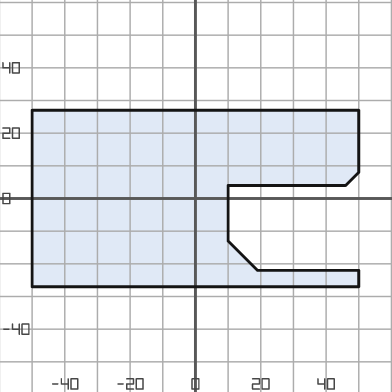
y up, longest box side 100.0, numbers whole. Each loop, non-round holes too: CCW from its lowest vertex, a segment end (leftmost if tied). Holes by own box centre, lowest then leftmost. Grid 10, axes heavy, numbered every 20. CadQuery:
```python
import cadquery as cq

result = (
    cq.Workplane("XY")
    .moveTo(-50.0, -27.0)
    .lineTo(50.0, -27.0)
    .lineTo(50.0, -22.0)
    .lineTo(19.0, -22.0)
    .lineTo(10.0, -13.0)
    .lineTo(10.0, 4.0)
    .lineTo(46.0, 4.0)
    .lineTo(50.0, 8.0)
    .lineTo(50.0, 27.0)
    .lineTo(-50.0, 27.0)
    .close()
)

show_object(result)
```